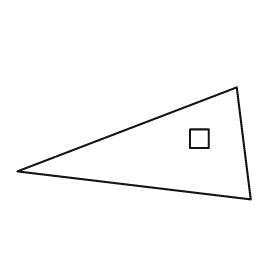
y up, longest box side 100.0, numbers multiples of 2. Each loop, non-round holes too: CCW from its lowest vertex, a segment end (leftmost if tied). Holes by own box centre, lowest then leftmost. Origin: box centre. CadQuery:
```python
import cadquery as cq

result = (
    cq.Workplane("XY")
    .moveTo(50.0, -24.0)
    .lineTo(44.0, 24.0)
    .lineTo(-50.0, -12.0)
    .close()
    .moveTo(24.0, -2.0)
    .lineTo(32.0, -2.0)
    .lineTo(32.0, 6.0)
    .lineTo(24.0, 6.0)
    .close()
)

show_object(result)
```